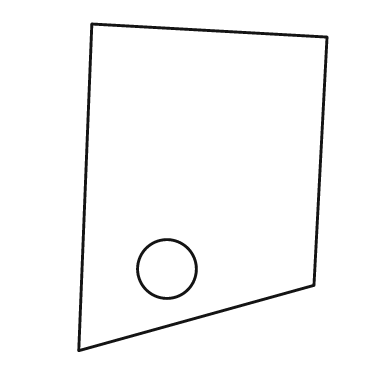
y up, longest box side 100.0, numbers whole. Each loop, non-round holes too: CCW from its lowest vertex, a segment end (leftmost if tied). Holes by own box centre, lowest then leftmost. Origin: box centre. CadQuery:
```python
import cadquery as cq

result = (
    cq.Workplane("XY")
    .moveTo(-38.0, -50.0)
    .lineTo(34.0, -30.0)
    .lineTo(38.0, 46.0)
    .lineTo(-34.0, 50.0)
    .close()
    .moveTo(-11.0, -25.0)
    .circle(9.0)
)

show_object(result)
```